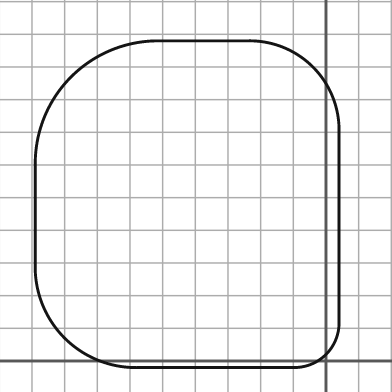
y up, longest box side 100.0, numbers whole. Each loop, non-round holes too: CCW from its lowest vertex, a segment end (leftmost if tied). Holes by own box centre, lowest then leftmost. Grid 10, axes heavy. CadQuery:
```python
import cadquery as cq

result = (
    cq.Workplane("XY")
    .moveTo(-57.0, -2.0)
    .lineTo(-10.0, -2.0)
    .threePointArc((0.0, 2.0), (4.0, 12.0))
    .lineTo(4.0, 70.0)
    .threePointArc((-4.0, 90.0), (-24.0, 98.0))
    .lineTo(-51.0, 98.0)
    .threePointArc((-78.0, 87.0), (-89.0, 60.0))
    .lineTo(-89.0, 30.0)
    .threePointArc((-80.0, 7.0), (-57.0, -2.0))
    .close()
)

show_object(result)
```